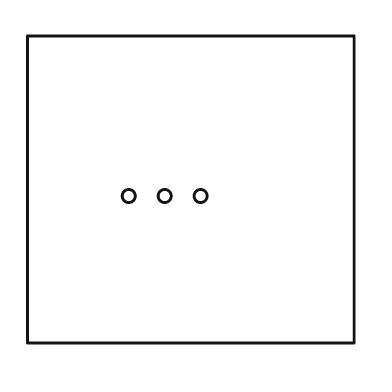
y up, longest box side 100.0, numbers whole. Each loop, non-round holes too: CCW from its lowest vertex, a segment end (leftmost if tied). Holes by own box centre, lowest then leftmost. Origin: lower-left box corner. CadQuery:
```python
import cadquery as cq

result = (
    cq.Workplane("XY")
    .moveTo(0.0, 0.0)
    .lineTo(100.0, 0.0)
    .lineTo(100.0, 94.0)
    .lineTo(0.0, 94.0)
    .close()
    .moveTo(31.0, 45.0)
    .circle(2.0)
    .moveTo(42.0, 45.0)
    .circle(2.0)
    .moveTo(53.0, 45.0)
    .circle(2.0)
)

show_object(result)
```